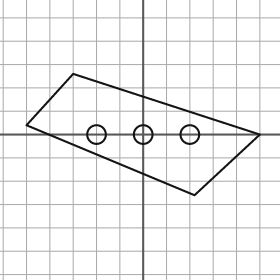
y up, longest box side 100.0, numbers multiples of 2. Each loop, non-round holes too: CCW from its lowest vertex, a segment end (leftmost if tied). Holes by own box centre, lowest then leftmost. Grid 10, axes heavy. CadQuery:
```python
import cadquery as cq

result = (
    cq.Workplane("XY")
    .moveTo(22.0, -26.0)
    .lineTo(50.0, 0.0)
    .lineTo(-30.0, 26.0)
    .lineTo(-50.0, 4.0)
    .close()
    .moveTo(-20.0, 0.0)
    .circle(4.0)
    .moveTo(0.0, 0.0)
    .circle(4.0)
    .moveTo(20.0, 0.0)
    .circle(4.0)
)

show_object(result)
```